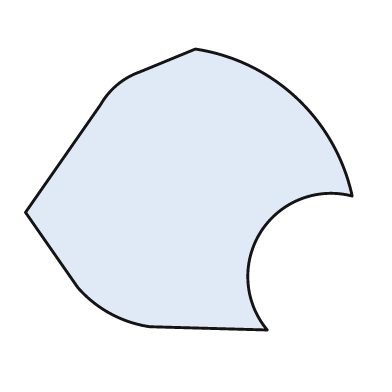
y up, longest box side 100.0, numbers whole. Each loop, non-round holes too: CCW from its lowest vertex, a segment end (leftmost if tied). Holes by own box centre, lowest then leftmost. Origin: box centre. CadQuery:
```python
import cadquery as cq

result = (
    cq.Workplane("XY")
    .moveTo(24.0, -43.0)
    .threePointArc((22.0, -13.0), (50.0, -2.0))
    .threePointArc((33.0, 28.0), (2.0, 43.0))
    .lineTo(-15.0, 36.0)
    .threePointArc((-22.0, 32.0), (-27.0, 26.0))
    .lineTo(-50.0, -7.0)
    .lineTo(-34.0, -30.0)
    .threePointArc((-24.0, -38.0), (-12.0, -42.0))
    .close()
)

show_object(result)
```